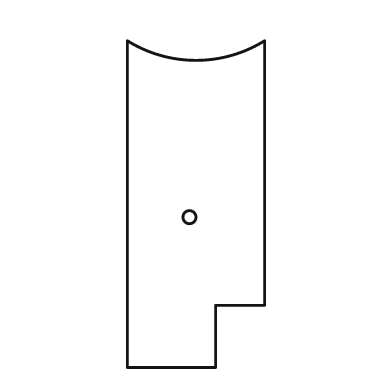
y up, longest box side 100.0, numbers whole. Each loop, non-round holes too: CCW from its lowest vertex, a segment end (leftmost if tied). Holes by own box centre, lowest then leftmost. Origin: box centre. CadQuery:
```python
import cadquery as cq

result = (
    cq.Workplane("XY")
    .moveTo(-21.0, -50.0)
    .lineTo(6.0, -50.0)
    .lineTo(6.0, -31.0)
    .lineTo(21.0, -31.0)
    .lineTo(21.0, 50.0)
    .threePointArc((0.0, 44.0), (-21.0, 50.0))
    .close()
    .moveTo(-2.0, -4.0)
    .circle(2.0)
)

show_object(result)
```